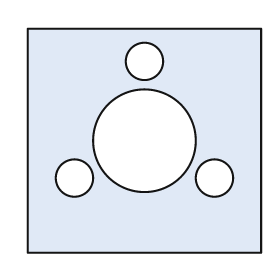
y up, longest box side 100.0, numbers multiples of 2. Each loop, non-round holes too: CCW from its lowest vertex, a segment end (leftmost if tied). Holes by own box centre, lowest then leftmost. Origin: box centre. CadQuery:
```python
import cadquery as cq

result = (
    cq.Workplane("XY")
    .moveTo(-50.0, -48.0)
    .lineTo(50.0, -48.0)
    .lineTo(50.0, 48.0)
    .lineTo(-50.0, 48.0)
    .close()
    .moveTo(-30.0, -16.0)
    .circle(8.0)
    .moveTo(30.0, -16.0)
    .circle(8.0)
    .moveTo(0.0, 0.0)
    .circle(22.0)
    .moveTo(0.0, 34.0)
    .circle(8.0)
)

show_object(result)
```